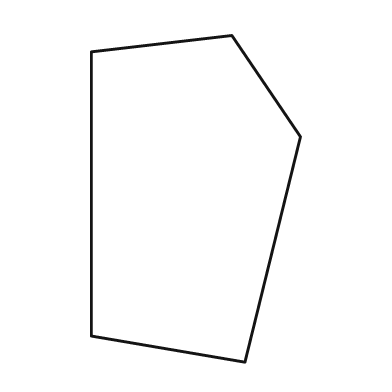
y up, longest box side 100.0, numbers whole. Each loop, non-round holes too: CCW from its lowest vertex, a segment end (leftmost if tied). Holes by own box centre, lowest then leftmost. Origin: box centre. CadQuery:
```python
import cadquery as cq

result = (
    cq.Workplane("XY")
    .moveTo(15.0, -50.0)
    .lineTo(32.0, 19.0)
    .lineTo(11.0, 50.0)
    .lineTo(-32.0, 45.0)
    .lineTo(-32.0, -42.0)
    .close()
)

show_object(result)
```